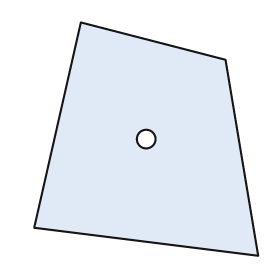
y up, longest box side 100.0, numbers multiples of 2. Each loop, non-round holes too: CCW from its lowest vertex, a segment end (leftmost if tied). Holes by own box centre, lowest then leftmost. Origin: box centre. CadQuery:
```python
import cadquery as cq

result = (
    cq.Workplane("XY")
    .moveTo(48.0, -50.0)
    .lineTo(34.0, 34.0)
    .lineTo(-28.0, 50.0)
    .lineTo(-48.0, -38.0)
    .close()
    .moveTo(0.0, 0.0)
    .circle(4.0)
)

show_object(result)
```